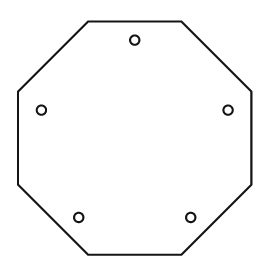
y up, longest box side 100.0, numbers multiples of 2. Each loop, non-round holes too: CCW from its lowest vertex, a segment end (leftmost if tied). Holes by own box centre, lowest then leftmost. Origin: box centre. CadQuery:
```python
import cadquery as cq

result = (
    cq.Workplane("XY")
    .moveTo(-20.0, -50.0)
    .lineTo(20.0, -50.0)
    .lineTo(50.0, -20.0)
    .lineTo(50.0, 20.0)
    .lineTo(20.0, 50.0)
    .lineTo(-20.0, 50.0)
    .lineTo(-50.0, 20.0)
    .lineTo(-50.0, -20.0)
    .close()
    .moveTo(-24.0, -34.0)
    .circle(2.0)
    .moveTo(24.0, -34.0)
    .circle(2.0)
    .moveTo(-40.0, 12.0)
    .circle(2.0)
    .moveTo(40.0, 12.0)
    .circle(2.0)
    .moveTo(0.0, 42.0)
    .circle(2.0)
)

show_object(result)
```